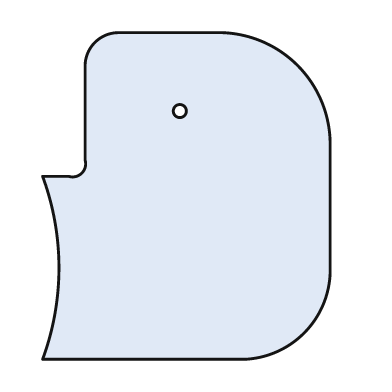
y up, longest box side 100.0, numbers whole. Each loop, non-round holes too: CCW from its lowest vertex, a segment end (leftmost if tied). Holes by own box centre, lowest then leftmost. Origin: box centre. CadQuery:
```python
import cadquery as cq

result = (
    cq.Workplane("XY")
    .moveTo(-44.0, -50.0)
    .lineTo(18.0, -50.0)
    .threePointArc((36.0, -42.0), (44.0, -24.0))
    .lineTo(44.0, 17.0)
    .threePointArc((34.0, 40.0), (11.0, 50.0))
    .lineTo(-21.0, 50.0)
    .threePointArc((-28.0, 47.0), (-31.0, 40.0))
    .lineTo(-31.0, 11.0)
    .threePointArc((-32.0, 7.0), (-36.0, 6.0))
    .lineTo(-44.0, 6.0)
    .threePointArc((-39.0, -22.0), (-44.0, -50.0))
    .close()
    .moveTo(-2.0, 26.0)
    .circle(2.0)
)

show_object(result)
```